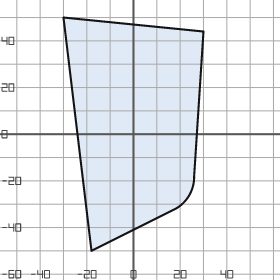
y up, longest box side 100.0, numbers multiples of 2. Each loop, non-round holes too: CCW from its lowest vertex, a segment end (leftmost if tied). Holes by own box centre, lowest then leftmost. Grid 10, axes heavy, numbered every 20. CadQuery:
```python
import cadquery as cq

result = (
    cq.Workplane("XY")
    .moveTo(-18.0, -50.0)
    .lineTo(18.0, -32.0)
    .threePointArc((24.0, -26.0), (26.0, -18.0))
    .lineTo(30.0, 44.0)
    .lineTo(-30.0, 50.0)
    .close()
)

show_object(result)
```